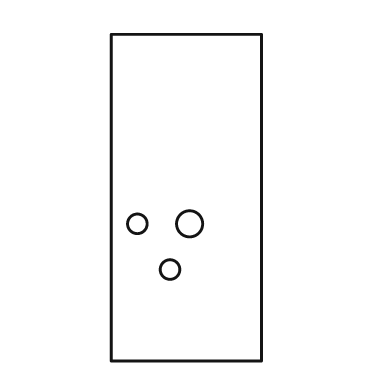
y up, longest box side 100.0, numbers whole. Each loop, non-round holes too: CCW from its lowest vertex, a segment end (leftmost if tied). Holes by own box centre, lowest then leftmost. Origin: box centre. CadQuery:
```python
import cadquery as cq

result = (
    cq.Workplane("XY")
    .moveTo(-23.0, -50.0)
    .lineTo(23.0, -50.0)
    .lineTo(23.0, 50.0)
    .lineTo(-23.0, 50.0)
    .close()
    .moveTo(-5.0, -22.0)
    .circle(3.0)
    .moveTo(-15.0, -8.0)
    .circle(3.0)
    .moveTo(1.0, -8.0)
    .circle(4.0)
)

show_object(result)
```